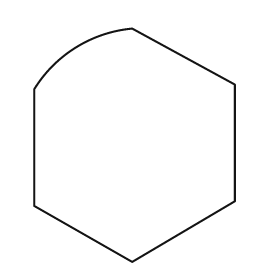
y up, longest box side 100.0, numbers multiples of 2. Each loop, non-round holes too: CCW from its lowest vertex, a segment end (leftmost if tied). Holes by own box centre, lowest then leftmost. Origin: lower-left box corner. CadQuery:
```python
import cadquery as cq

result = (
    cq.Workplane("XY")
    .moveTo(42.0, 0.0)
    .lineTo(86.0, 26.0)
    .lineTo(86.0, 76.0)
    .lineTo(42.0, 100.0)
    .threePointArc((18.0, 92.0), (0.0, 74.0))
    .lineTo(0.0, 24.0)
    .close()
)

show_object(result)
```